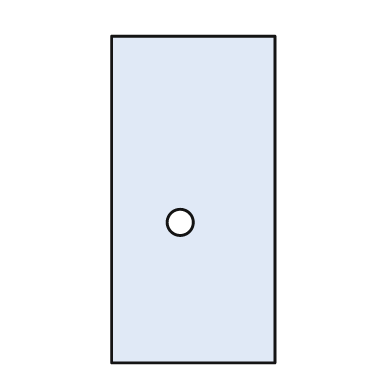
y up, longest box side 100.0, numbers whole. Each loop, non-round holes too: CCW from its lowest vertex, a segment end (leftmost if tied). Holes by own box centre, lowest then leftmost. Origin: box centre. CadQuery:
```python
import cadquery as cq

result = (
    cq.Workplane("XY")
    .moveTo(-25.0, -50.0)
    .lineTo(25.0, -50.0)
    .lineTo(25.0, 50.0)
    .lineTo(-25.0, 50.0)
    .close()
    .moveTo(-4.0, -7.0)
    .circle(4.0)
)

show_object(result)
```